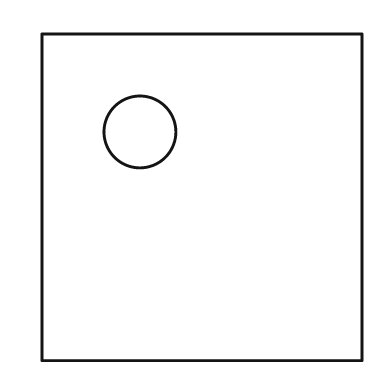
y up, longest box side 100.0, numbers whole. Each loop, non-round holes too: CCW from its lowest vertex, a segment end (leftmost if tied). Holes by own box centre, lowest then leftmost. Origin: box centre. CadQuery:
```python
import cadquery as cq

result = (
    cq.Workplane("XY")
    .moveTo(-49.0, -50.0)
    .lineTo(49.0, -50.0)
    .lineTo(49.0, 50.0)
    .lineTo(-49.0, 50.0)
    .close()
    .moveTo(-19.0, 20.0)
    .circle(11.0)
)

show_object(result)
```